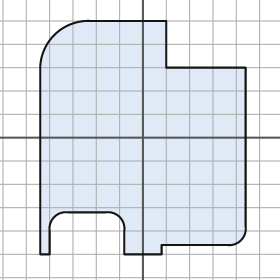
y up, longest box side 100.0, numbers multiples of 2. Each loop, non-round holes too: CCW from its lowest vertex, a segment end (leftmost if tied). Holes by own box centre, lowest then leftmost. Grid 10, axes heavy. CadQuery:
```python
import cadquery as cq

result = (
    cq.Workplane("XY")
    .moveTo(-44.0, -50.0)
    .lineTo(-40.0, -50.0)
    .lineTo(-40.0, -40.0)
    .threePointArc((-38.0, -34.0), (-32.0, -32.0))
    .lineTo(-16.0, -32.0)
    .threePointArc((-10.0, -34.0), (-8.0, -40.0))
    .lineTo(-8.0, -50.0)
    .lineTo(8.0, -50.0)
    .lineTo(8.0, -46.0)
    .lineTo(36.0, -46.0)
    .threePointArc((42.0, -44.0), (44.0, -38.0))
    .lineTo(44.0, 30.0)
    .lineTo(10.0, 30.0)
    .lineTo(10.0, 50.0)
    .lineTo(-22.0, 50.0)
    .threePointArc((-38.0, 44.0), (-44.0, 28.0))
    .close()
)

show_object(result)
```